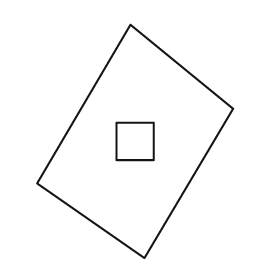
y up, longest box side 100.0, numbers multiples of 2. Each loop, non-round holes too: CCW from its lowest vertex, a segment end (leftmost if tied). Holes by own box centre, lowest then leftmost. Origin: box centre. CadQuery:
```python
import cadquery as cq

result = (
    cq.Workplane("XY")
    .moveTo(4.0, -50.0)
    .lineTo(42.0, 14.0)
    .lineTo(-2.0, 50.0)
    .lineTo(-42.0, -18.0)
    .close()
    .moveTo(-8.0, -8.0)
    .lineTo(8.0, -8.0)
    .lineTo(8.0, 8.0)
    .lineTo(-8.0, 8.0)
    .close()
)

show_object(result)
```